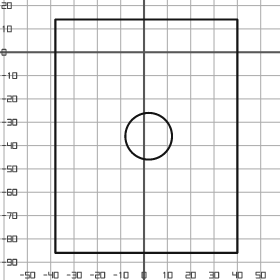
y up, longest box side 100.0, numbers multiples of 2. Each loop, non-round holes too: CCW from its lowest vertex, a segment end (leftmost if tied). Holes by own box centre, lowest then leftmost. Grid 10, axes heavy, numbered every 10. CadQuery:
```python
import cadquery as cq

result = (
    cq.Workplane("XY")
    .moveTo(-38.0, -86.0)
    .lineTo(40.0, -86.0)
    .lineTo(40.0, 14.0)
    .lineTo(-38.0, 14.0)
    .close()
    .moveTo(2.0, -36.0)
    .circle(10.0)
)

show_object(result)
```